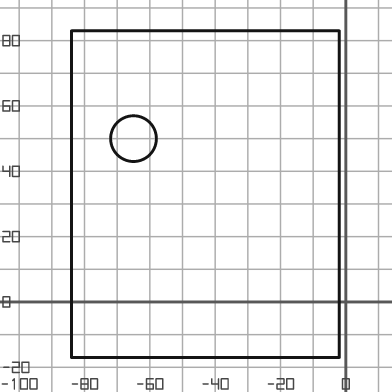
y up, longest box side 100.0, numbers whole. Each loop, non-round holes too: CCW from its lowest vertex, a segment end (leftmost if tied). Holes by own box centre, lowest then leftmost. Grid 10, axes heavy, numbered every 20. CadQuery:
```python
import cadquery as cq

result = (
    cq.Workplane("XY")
    .moveTo(-84.0, -17.0)
    .lineTo(-2.0, -17.0)
    .lineTo(-2.0, 83.0)
    .lineTo(-84.0, 83.0)
    .close()
    .moveTo(-65.0, 50.0)
    .circle(7.0)
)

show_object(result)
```